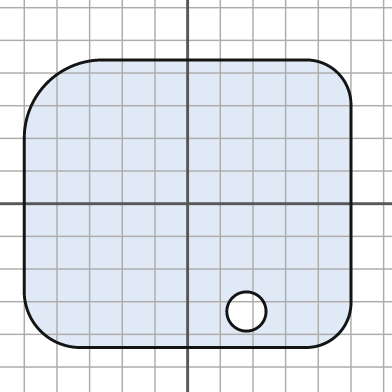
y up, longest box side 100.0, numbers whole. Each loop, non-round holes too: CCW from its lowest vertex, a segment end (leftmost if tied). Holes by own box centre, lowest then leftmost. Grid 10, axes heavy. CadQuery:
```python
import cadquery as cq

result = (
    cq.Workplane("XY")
    .moveTo(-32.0, -44.0)
    .lineTo(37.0, -44.0)
    .threePointArc((46.0, -40.0), (50.0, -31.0))
    .lineTo(50.0, 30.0)
    .threePointArc((46.0, 40.0), (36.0, 44.0))
    .lineTo(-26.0, 44.0)
    .threePointArc((-43.0, 37.0), (-50.0, 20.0))
    .lineTo(-50.0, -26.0)
    .threePointArc((-45.0, -39.0), (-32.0, -44.0))
    .close()
    .moveTo(18.0, -33.0)
    .circle(6.0)
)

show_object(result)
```